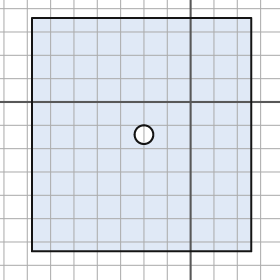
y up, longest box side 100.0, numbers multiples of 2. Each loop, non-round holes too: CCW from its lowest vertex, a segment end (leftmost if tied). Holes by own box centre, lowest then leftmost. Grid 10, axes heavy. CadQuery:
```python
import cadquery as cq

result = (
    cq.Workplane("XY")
    .moveTo(-68.0, -64.0)
    .lineTo(26.0, -64.0)
    .lineTo(26.0, 36.0)
    .lineTo(-68.0, 36.0)
    .close()
    .moveTo(-20.0, -14.0)
    .circle(4.0)
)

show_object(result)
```